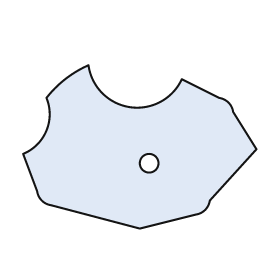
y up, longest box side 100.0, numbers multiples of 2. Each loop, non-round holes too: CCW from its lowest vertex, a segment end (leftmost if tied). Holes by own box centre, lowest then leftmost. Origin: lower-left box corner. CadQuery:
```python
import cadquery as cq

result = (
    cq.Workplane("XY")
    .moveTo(50.0, 0.0)
    .lineTo(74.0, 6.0)
    .threePointArc((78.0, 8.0), (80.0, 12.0))
    .lineTo(100.0, 34.0)
    .lineTo(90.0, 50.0)
    .threePointArc((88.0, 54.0), (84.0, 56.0))
    .lineTo(68.0, 64.0)
    .threePointArc((46.0, 52.0), (28.0, 70.0))
    .threePointArc((18.0, 64.0), (10.0, 56.0))
    .threePointArc((10.0, 42.0), (0.0, 32.0))
    .lineTo(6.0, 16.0)
    .threePointArc((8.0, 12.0), (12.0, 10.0))
    .close()
    .moveTo(54.0, 28.0)
    .circle(4.0)
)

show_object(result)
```